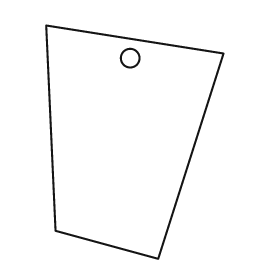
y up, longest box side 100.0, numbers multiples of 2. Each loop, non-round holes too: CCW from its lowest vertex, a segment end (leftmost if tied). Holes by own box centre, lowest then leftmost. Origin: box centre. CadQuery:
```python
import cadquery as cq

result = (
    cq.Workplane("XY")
    .moveTo(10.0, -50.0)
    .lineTo(38.0, 38.0)
    .lineTo(-38.0, 50.0)
    .lineTo(-34.0, -38.0)
    .close()
    .moveTo(-2.0, 36.0)
    .circle(4.0)
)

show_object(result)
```